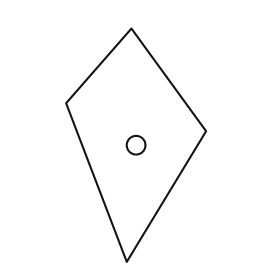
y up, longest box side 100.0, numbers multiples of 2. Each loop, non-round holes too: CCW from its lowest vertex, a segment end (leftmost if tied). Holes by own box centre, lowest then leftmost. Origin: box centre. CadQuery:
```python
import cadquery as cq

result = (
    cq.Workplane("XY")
    .moveTo(-4.0, -50.0)
    .lineTo(30.0, 6.0)
    .lineTo(-2.0, 50.0)
    .lineTo(-30.0, 18.0)
    .close()
    .moveTo(0.0, 0.0)
    .circle(4.0)
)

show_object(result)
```